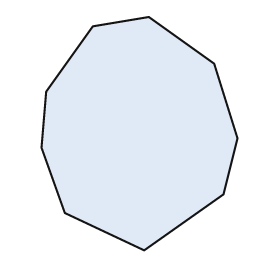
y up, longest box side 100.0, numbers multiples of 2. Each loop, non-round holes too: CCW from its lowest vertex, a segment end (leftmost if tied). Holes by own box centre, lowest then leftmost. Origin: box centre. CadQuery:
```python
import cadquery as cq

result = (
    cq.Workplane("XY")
    .moveTo(2.0, -50.0)
    .lineTo(36.0, -26.0)
    .lineTo(42.0, -2.0)
    .lineTo(32.0, 30.0)
    .lineTo(4.0, 50.0)
    .lineTo(-20.0, 46.0)
    .lineTo(-40.0, 18.0)
    .lineTo(-42.0, -6.0)
    .lineTo(-32.0, -34.0)
    .close()
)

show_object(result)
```